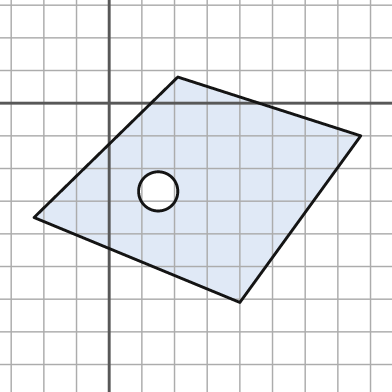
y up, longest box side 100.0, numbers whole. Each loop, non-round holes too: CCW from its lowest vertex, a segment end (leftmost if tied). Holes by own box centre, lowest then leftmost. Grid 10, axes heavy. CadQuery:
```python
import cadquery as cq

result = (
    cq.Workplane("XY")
    .moveTo(40.0, -61.0)
    .lineTo(77.0, -10.0)
    .lineTo(21.0, 8.0)
    .lineTo(-23.0, -35.0)
    .close()
    .moveTo(15.0, -27.0)
    .circle(6.0)
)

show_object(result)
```